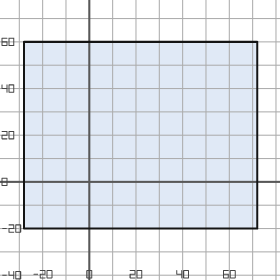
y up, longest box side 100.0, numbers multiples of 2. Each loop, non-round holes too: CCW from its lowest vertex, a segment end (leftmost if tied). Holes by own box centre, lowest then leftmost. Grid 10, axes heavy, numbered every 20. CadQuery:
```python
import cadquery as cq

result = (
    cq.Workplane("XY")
    .moveTo(-28.0, -20.0)
    .lineTo(72.0, -20.0)
    .lineTo(72.0, 60.0)
    .lineTo(-28.0, 60.0)
    .close()
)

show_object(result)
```